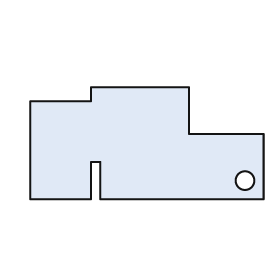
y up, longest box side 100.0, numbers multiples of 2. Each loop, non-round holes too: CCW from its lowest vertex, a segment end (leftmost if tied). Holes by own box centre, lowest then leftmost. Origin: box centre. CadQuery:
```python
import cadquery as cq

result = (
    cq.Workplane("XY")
    .moveTo(-50.0, -24.0)
    .lineTo(-24.0, -24.0)
    .lineTo(-24.0, -8.0)
    .lineTo(-20.0, -8.0)
    .lineTo(-20.0, -24.0)
    .lineTo(50.0, -24.0)
    .lineTo(50.0, 4.0)
    .lineTo(18.0, 4.0)
    .lineTo(18.0, 24.0)
    .lineTo(-24.0, 24.0)
    .lineTo(-24.0, 18.0)
    .lineTo(-50.0, 18.0)
    .close()
    .moveTo(42.0, -16.0)
    .circle(4.0)
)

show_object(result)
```